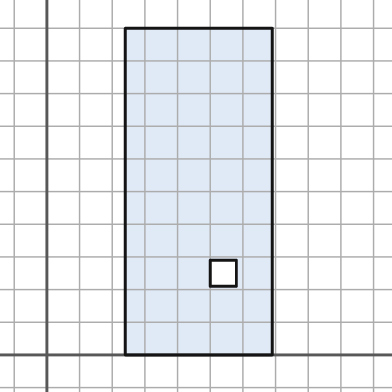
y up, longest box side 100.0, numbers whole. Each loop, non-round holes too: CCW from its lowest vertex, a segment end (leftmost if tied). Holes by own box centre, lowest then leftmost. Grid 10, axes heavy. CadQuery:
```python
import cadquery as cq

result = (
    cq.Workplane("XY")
    .moveTo(24.0, 0.0)
    .lineTo(69.0, 0.0)
    .lineTo(69.0, 100.0)
    .lineTo(24.0, 100.0)
    .close()
    .moveTo(50.0, 21.0)
    .lineTo(58.0, 21.0)
    .lineTo(58.0, 29.0)
    .lineTo(50.0, 29.0)
    .close()
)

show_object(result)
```